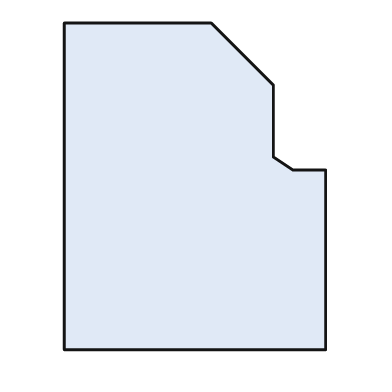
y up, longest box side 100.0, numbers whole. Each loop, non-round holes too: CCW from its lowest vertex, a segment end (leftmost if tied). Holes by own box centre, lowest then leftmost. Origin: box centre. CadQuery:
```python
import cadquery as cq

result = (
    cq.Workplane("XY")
    .moveTo(-40.0, -50.0)
    .lineTo(40.0, -50.0)
    .lineTo(40.0, 5.0)
    .lineTo(30.0, 5.0)
    .lineTo(24.0, 9.0)
    .lineTo(24.0, 31.0)
    .lineTo(5.0, 50.0)
    .lineTo(-40.0, 50.0)
    .close()
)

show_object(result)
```